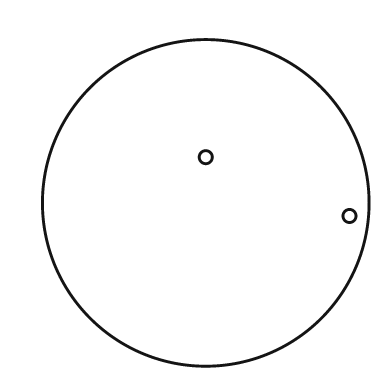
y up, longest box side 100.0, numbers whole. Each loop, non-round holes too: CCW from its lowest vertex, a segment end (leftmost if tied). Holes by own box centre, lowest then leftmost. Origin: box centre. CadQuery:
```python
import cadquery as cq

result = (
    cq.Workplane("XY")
    .moveTo(0.0, 0.0)
    .circle(50.0)
    .moveTo(44.0, -4.0)
    .circle(2.0)
    .moveTo(0.0, 14.0)
    .circle(2.0)
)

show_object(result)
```